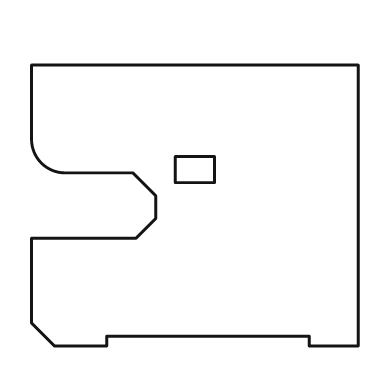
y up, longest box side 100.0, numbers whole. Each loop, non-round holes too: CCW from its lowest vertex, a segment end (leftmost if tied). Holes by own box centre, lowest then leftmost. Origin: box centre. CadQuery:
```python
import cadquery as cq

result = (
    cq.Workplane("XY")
    .moveTo(-43.0, -43.0)
    .lineTo(-27.0, -43.0)
    .lineTo(-27.0, -40.0)
    .lineTo(35.0, -40.0)
    .lineTo(35.0, -43.0)
    .lineTo(50.0, -43.0)
    .lineTo(50.0, 43.0)
    .lineTo(-50.0, 43.0)
    .lineTo(-50.0, 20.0)
    .threePointArc((-47.0, 13.0), (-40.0, 10.0))
    .lineTo(-19.0, 10.0)
    .lineTo(-12.0, 3.0)
    .lineTo(-12.0, -4.0)
    .lineTo(-18.0, -10.0)
    .lineTo(-50.0, -10.0)
    .lineTo(-50.0, -36.0)
    .close()
    .moveTo(-6.0, 7.0)
    .lineTo(6.0, 7.0)
    .lineTo(6.0, 15.0)
    .lineTo(-6.0, 15.0)
    .close()
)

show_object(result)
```